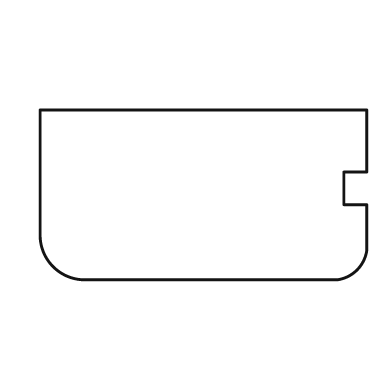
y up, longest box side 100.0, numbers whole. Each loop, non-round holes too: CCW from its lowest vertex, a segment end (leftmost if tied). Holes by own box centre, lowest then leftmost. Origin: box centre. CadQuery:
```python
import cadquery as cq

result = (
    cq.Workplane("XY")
    .moveTo(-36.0, -26.0)
    .lineTo(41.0, -26.0)
    .threePointArc((47.0, -23.0), (50.0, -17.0))
    .lineTo(50.0, -3.0)
    .lineTo(43.0, -3.0)
    .lineTo(43.0, 7.0)
    .lineTo(50.0, 7.0)
    .lineTo(50.0, 26.0)
    .lineTo(-50.0, 26.0)
    .lineTo(-50.0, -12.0)
    .threePointArc((-46.0, -22.0), (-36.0, -26.0))
    .close()
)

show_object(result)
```